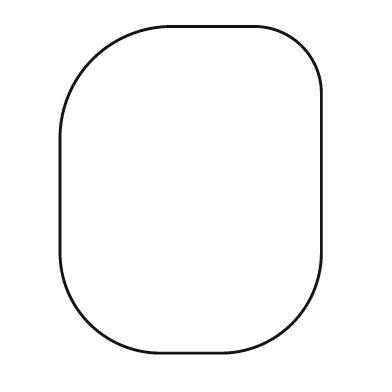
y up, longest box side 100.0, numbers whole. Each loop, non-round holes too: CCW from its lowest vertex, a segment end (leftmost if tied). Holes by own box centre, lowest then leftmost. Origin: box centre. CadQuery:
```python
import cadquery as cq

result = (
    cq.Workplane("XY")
    .moveTo(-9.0, -50.0)
    .lineTo(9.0, -50.0)
    .threePointArc((31.0, -41.0), (40.0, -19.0))
    .lineTo(40.0, 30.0)
    .threePointArc((34.0, 44.0), (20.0, 50.0))
    .lineTo(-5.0, 50.0)
    .threePointArc((-30.0, 40.0), (-40.0, 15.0))
    .lineTo(-40.0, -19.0)
    .threePointArc((-31.0, -41.0), (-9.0, -50.0))
    .close()
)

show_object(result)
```